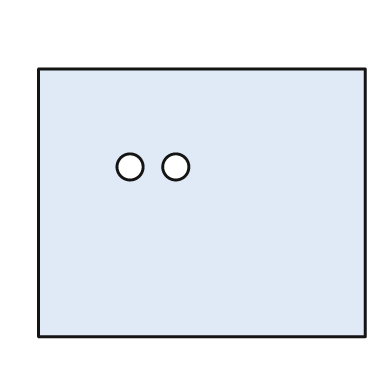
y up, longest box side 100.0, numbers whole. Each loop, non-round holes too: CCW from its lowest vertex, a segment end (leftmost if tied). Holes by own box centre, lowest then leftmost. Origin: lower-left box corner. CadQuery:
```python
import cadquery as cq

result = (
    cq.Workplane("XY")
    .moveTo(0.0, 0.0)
    .lineTo(100.0, 0.0)
    .lineTo(100.0, 82.0)
    .lineTo(0.0, 82.0)
    .close()
    .moveTo(28.0, 52.0)
    .circle(4.0)
    .moveTo(42.0, 52.0)
    .circle(4.0)
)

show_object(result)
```